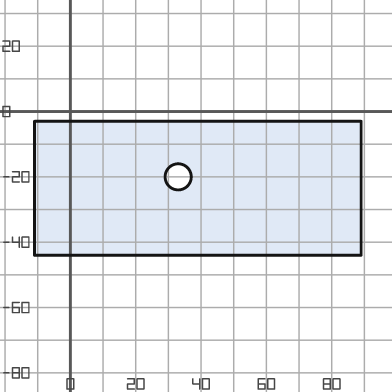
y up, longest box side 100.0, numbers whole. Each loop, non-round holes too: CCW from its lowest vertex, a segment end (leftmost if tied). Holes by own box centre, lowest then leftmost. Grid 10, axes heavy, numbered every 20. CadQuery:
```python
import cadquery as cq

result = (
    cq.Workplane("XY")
    .moveTo(-11.0, -44.0)
    .lineTo(89.0, -44.0)
    .lineTo(89.0, -3.0)
    .lineTo(-11.0, -3.0)
    .close()
    .moveTo(33.0, -20.0)
    .circle(4.0)
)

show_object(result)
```